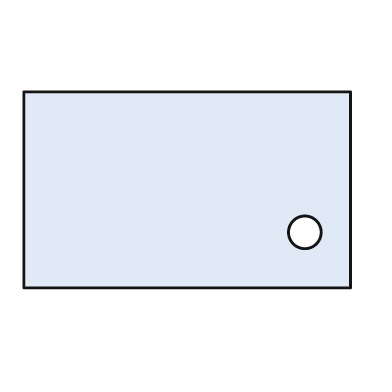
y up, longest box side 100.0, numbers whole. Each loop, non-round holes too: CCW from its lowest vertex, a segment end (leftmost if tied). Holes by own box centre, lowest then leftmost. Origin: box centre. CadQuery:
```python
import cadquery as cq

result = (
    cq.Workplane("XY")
    .moveTo(-50.0, -30.0)
    .lineTo(50.0, -30.0)
    .lineTo(50.0, 30.0)
    .lineTo(-50.0, 30.0)
    .close()
    .moveTo(36.0, -13.0)
    .circle(5.0)
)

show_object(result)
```